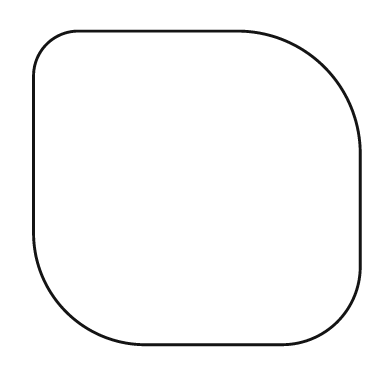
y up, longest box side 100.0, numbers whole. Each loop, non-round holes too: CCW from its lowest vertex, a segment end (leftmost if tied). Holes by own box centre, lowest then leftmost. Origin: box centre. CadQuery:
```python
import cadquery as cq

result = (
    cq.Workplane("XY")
    .moveTo(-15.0, -48.0)
    .lineTo(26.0, -48.0)
    .threePointArc((43.0, -41.0), (50.0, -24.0))
    .lineTo(50.0, 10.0)
    .threePointArc((39.0, 37.0), (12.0, 48.0))
    .lineTo(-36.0, 48.0)
    .threePointArc((-46.0, 44.0), (-50.0, 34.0))
    .lineTo(-50.0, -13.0)
    .threePointArc((-40.0, -38.0), (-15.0, -48.0))
    .close()
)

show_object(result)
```